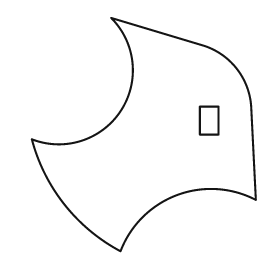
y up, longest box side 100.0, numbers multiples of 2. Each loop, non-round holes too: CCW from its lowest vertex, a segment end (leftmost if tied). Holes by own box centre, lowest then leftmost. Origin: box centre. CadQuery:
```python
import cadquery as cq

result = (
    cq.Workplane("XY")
    .moveTo(-10.0, -50.0)
    .threePointArc((14.0, -26.0), (48.0, -28.0))
    .lineTo(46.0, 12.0)
    .threePointArc((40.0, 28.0), (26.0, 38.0))
    .lineTo(-14.0, 50.0)
    .threePointArc((-10.0, 10.0), (-48.0, -2.0))
    .threePointArc((-34.0, -30.0), (-10.0, -50.0))
    .close()
    .moveTo(24.0, 0.0)
    .lineTo(32.0, 0.0)
    .lineTo(32.0, 12.0)
    .lineTo(24.0, 12.0)
    .close()
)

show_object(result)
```